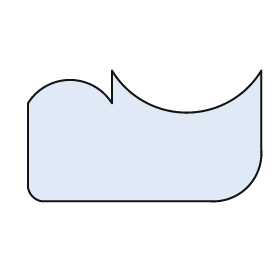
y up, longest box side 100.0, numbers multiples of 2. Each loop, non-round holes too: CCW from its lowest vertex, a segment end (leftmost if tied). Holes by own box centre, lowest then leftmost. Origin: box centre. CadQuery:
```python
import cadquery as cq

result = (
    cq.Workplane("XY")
    .moveTo(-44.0, -28.0)
    .lineTo(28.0, -28.0)
    .threePointArc((44.0, -22.0), (50.0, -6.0))
    .lineTo(50.0, 28.0)
    .threePointArc((18.0, 10.0), (-14.0, 28.0))
    .lineTo(-14.0, 14.0)
    .threePointArc((-32.0, 24.0), (-50.0, 14.0))
    .lineTo(-50.0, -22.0)
    .threePointArc((-48.0, -26.0), (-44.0, -28.0))
    .close()
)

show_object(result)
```